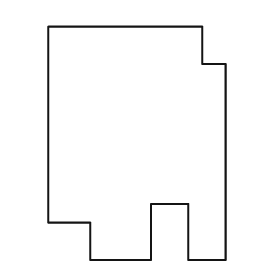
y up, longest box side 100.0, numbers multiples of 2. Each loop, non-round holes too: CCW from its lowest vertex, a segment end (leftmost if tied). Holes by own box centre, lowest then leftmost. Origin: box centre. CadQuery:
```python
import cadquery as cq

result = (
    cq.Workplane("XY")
    .moveTo(-20.0, -50.0)
    .lineTo(6.0, -50.0)
    .lineTo(6.0, -26.0)
    .lineTo(22.0, -26.0)
    .lineTo(22.0, -50.0)
    .lineTo(38.0, -50.0)
    .lineTo(38.0, 34.0)
    .lineTo(28.0, 34.0)
    .lineTo(28.0, 50.0)
    .lineTo(-38.0, 50.0)
    .lineTo(-38.0, -34.0)
    .lineTo(-20.0, -34.0)
    .close()
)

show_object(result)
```